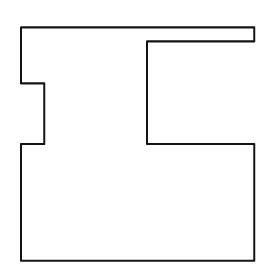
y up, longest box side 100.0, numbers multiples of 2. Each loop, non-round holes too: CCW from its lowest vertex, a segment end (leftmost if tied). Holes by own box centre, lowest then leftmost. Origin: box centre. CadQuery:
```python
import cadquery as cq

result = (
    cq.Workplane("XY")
    .moveTo(-50.0, -50.0)
    .lineTo(50.0, -50.0)
    .lineTo(50.0, 0.0)
    .lineTo(4.0, 0.0)
    .lineTo(4.0, 44.0)
    .lineTo(50.0, 44.0)
    .lineTo(50.0, 50.0)
    .lineTo(-50.0, 50.0)
    .lineTo(-50.0, 26.0)
    .lineTo(-40.0, 26.0)
    .lineTo(-40.0, 0.0)
    .lineTo(-50.0, 0.0)
    .close()
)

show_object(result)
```